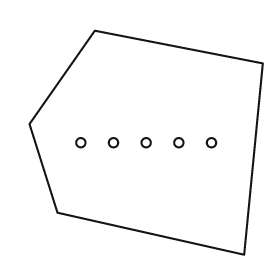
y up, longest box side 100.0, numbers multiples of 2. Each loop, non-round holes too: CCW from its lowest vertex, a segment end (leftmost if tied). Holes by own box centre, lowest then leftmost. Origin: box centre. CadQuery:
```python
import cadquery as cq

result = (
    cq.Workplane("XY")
    .moveTo(42.0, -48.0)
    .lineTo(50.0, 34.0)
    .lineTo(-22.0, 48.0)
    .lineTo(-50.0, 8.0)
    .lineTo(-38.0, -30.0)
    .close()
    .moveTo(-28.0, 0.0)
    .circle(2.0)
    .moveTo(-14.0, 0.0)
    .circle(2.0)
    .moveTo(0.0, 0.0)
    .circle(2.0)
    .moveTo(14.0, 0.0)
    .circle(2.0)
    .moveTo(28.0, 0.0)
    .circle(2.0)
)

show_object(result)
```